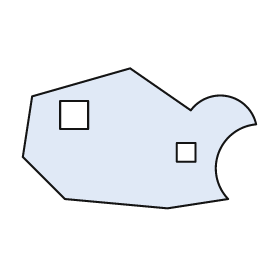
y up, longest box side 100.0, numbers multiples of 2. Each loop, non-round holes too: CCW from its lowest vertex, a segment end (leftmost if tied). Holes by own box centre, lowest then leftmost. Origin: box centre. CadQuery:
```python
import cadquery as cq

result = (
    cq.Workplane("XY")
    .moveTo(12.0, -30.0)
    .lineTo(38.0, -26.0)
    .threePointArc((34.0, -6.0), (50.0, 6.0))
    .threePointArc((38.0, 18.0), (22.0, 12.0))
    .lineTo(-4.0, 30.0)
    .lineTo(-46.0, 18.0)
    .lineTo(-50.0, -8.0)
    .lineTo(-32.0, -26.0)
    .close()
    .moveTo(16.0, -10.0)
    .lineTo(24.0, -10.0)
    .lineTo(24.0, -2.0)
    .lineTo(16.0, -2.0)
    .close()
    .moveTo(-34.0, 4.0)
    .lineTo(-22.0, 4.0)
    .lineTo(-22.0, 16.0)
    .lineTo(-34.0, 16.0)
    .close()
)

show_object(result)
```